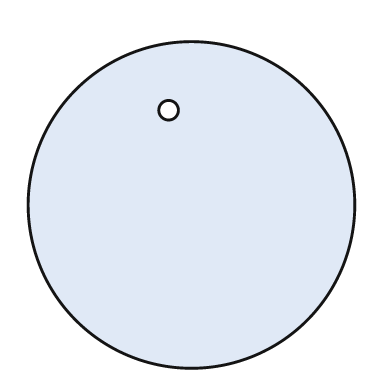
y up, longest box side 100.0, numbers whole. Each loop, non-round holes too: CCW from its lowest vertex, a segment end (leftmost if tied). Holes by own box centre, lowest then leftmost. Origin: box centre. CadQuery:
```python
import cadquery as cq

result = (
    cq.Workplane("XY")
    .moveTo(0.0, 0.0)
    .circle(50.0)
    .moveTo(-7.0, 29.0)
    .circle(3.0)
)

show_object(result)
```